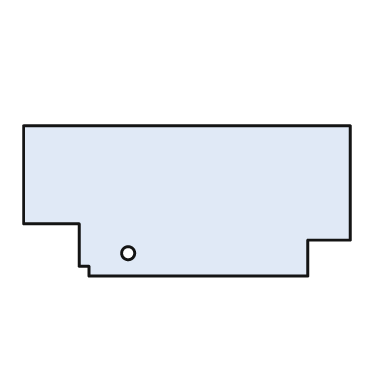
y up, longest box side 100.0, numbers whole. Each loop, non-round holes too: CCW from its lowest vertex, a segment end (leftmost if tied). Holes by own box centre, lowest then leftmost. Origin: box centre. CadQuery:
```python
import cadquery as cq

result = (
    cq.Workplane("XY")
    .moveTo(-30.0, -23.0)
    .lineTo(37.0, -23.0)
    .lineTo(37.0, -12.0)
    .lineTo(50.0, -12.0)
    .lineTo(50.0, 23.0)
    .lineTo(-50.0, 23.0)
    .lineTo(-50.0, -7.0)
    .lineTo(-33.0, -7.0)
    .lineTo(-33.0, -20.0)
    .lineTo(-30.0, -20.0)
    .close()
    .moveTo(-18.0, -16.0)
    .circle(2.0)
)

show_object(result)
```